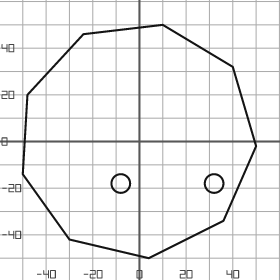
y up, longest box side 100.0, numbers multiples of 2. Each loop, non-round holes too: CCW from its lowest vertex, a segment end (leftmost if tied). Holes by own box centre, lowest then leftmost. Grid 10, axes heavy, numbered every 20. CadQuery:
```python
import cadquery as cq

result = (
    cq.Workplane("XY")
    .moveTo(4.0, -50.0)
    .lineTo(36.0, -34.0)
    .lineTo(50.0, -2.0)
    .lineTo(40.0, 32.0)
    .lineTo(10.0, 50.0)
    .lineTo(-24.0, 46.0)
    .lineTo(-48.0, 20.0)
    .lineTo(-50.0, -14.0)
    .lineTo(-30.0, -42.0)
    .close()
    .moveTo(-8.0, -18.0)
    .circle(4.0)
    .moveTo(32.0, -18.0)
    .circle(4.0)
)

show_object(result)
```